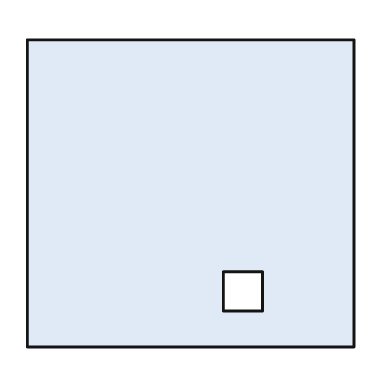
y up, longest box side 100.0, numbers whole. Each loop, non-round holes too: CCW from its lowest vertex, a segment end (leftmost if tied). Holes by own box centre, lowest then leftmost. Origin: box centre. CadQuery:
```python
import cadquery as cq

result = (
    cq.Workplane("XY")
    .moveTo(-50.0, -47.0)
    .lineTo(50.0, -47.0)
    .lineTo(50.0, 47.0)
    .lineTo(-50.0, 47.0)
    .close()
    .moveTo(10.0, -36.0)
    .lineTo(22.0, -36.0)
    .lineTo(22.0, -24.0)
    .lineTo(10.0, -24.0)
    .close()
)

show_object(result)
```